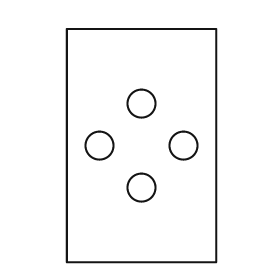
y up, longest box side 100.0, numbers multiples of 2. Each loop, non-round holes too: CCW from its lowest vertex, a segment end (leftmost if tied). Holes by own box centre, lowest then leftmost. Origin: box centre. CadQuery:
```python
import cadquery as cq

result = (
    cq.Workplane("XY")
    .moveTo(-32.0, -50.0)
    .lineTo(32.0, -50.0)
    .lineTo(32.0, 50.0)
    .lineTo(-32.0, 50.0)
    .close()
    .moveTo(0.0, -18.0)
    .circle(6.0)
    .moveTo(-18.0, 0.0)
    .circle(6.0)
    .moveTo(18.0, 0.0)
    .circle(6.0)
    .moveTo(0.0, 18.0)
    .circle(6.0)
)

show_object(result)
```